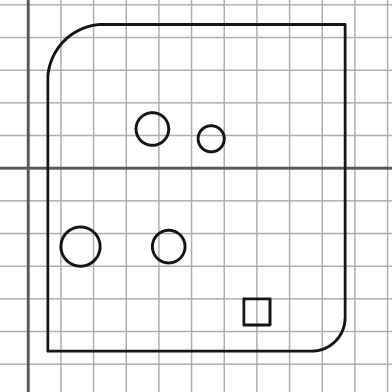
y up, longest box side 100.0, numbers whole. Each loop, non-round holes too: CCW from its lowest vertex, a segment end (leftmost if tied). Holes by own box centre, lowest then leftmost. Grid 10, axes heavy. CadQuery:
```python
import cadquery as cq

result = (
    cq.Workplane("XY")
    .moveTo(6.0, -56.0)
    .lineTo(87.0, -56.0)
    .threePointArc((94.0, -53.0), (97.0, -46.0))
    .lineTo(97.0, 44.0)
    .lineTo(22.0, 44.0)
    .threePointArc((11.0, 39.0), (6.0, 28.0))
    .close()
    .moveTo(66.0, -48.0)
    .lineTo(74.0, -48.0)
    .lineTo(74.0, -40.0)
    .lineTo(66.0, -40.0)
    .close()
    .moveTo(16.0, -24.0)
    .circle(6.0)
    .moveTo(43.0, -24.0)
    .circle(5.0)
    .moveTo(56.0, 9.0)
    .circle(4.0)
    .moveTo(38.0, 12.0)
    .circle(5.0)
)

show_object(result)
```